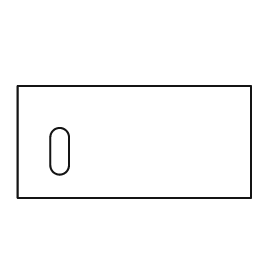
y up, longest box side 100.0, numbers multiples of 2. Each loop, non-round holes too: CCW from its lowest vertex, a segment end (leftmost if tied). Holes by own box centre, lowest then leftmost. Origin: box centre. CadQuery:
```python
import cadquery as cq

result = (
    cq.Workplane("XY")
    .moveTo(-50.0, -24.0)
    .lineTo(50.0, -24.0)
    .lineTo(50.0, 24.0)
    .lineTo(-50.0, 24.0)
    .close()
    .moveTo(-36.0, -10.0)
    .threePointArc((-32.0, -14.0), (-28.0, -10.0))
    .lineTo(-28.0, 2.0)
    .threePointArc((-32.0, 6.0), (-36.0, 2.0))
    .close()
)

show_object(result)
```